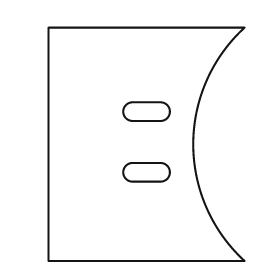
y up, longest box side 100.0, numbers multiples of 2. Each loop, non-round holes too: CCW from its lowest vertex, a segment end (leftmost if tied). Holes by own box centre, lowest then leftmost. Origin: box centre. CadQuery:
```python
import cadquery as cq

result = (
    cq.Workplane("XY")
    .moveTo(-42.0, -50.0)
    .lineTo(42.0, -50.0)
    .threePointArc((20.0, 0.0), (42.0, 50.0))
    .lineTo(-42.0, 50.0)
    .close()
    .moveTo(-6.0, -16.0)
    .lineTo(6.0, -16.0)
    .threePointArc((10.0, -12.0), (6.0, -8.0))
    .lineTo(-6.0, -8.0)
    .threePointArc((-10.0, -12.0), (-6.0, -16.0))
    .close()
    .moveTo(-6.0, 10.0)
    .lineTo(6.0, 10.0)
    .threePointArc((10.0, 14.0), (6.0, 18.0))
    .lineTo(-6.0, 18.0)
    .threePointArc((-10.0, 14.0), (-6.0, 10.0))
    .close()
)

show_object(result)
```